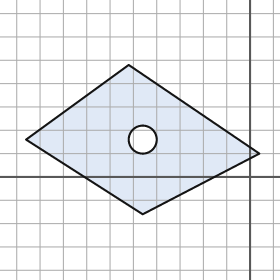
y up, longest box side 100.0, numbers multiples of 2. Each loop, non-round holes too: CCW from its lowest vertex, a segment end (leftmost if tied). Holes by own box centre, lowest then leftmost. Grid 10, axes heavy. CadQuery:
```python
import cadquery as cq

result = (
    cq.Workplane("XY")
    .moveTo(-46.0, -16.0)
    .lineTo(4.0, 10.0)
    .lineTo(-52.0, 48.0)
    .lineTo(-96.0, 16.0)
    .close()
    .moveTo(-46.0, 16.0)
    .circle(6.0)
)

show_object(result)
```